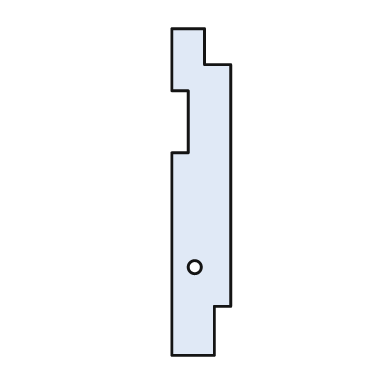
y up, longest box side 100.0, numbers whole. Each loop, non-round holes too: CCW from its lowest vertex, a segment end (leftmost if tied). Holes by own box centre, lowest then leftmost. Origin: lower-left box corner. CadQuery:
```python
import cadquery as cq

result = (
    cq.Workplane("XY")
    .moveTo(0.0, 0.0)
    .lineTo(13.0, 0.0)
    .lineTo(13.0, 15.0)
    .lineTo(18.0, 15.0)
    .lineTo(18.0, 89.0)
    .lineTo(10.0, 89.0)
    .lineTo(10.0, 100.0)
    .lineTo(0.0, 100.0)
    .lineTo(0.0, 81.0)
    .lineTo(5.0, 81.0)
    .lineTo(5.0, 62.0)
    .lineTo(0.0, 62.0)
    .close()
    .moveTo(7.0, 27.0)
    .circle(2.0)
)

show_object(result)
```